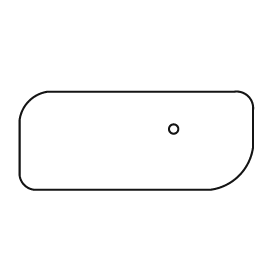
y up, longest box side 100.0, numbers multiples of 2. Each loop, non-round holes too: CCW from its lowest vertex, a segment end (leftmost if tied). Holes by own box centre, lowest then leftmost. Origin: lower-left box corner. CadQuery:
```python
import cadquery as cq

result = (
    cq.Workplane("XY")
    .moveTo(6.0, 0.0)
    .lineTo(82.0, 0.0)
    .threePointArc((94.0, 6.0), (100.0, 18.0))
    .lineTo(100.0, 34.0)
    .threePointArc((98.0, 40.0), (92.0, 42.0))
    .lineTo(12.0, 42.0)
    .threePointArc((4.0, 38.0), (0.0, 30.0))
    .lineTo(0.0, 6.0)
    .threePointArc((2.0, 2.0), (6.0, 0.0))
    .close()
    .moveTo(66.0, 26.0)
    .circle(2.0)
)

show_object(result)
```